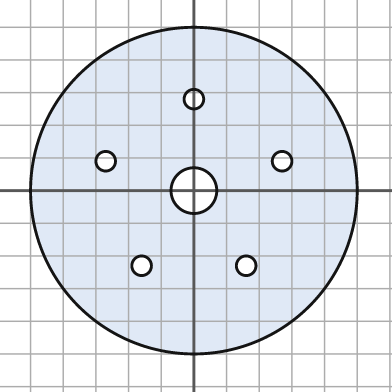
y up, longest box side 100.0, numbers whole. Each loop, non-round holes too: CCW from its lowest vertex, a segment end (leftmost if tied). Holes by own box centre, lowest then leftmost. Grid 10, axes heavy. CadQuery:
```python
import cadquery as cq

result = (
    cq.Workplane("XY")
    .moveTo(0.0, 0.0)
    .circle(50.0)
    .moveTo(-16.0, -23.0)
    .circle(3.0)
    .moveTo(16.0, -23.0)
    .circle(3.0)
    .moveTo(0.0, 0.0)
    .circle(7.0)
    .moveTo(-27.0, 9.0)
    .circle(3.0)
    .moveTo(27.0, 9.0)
    .circle(3.0)
    .moveTo(0.0, 28.0)
    .circle(3.0)
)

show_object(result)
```